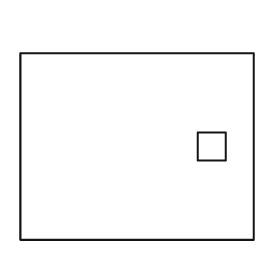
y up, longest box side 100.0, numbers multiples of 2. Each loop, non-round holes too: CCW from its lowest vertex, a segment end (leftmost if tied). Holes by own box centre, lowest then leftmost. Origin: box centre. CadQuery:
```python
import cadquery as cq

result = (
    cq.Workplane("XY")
    .moveTo(-50.0, -40.0)
    .lineTo(50.0, -40.0)
    .lineTo(50.0, 40.0)
    .lineTo(-50.0, 40.0)
    .close()
    .moveTo(26.0, -6.0)
    .lineTo(38.0, -6.0)
    .lineTo(38.0, 6.0)
    .lineTo(26.0, 6.0)
    .close()
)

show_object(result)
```